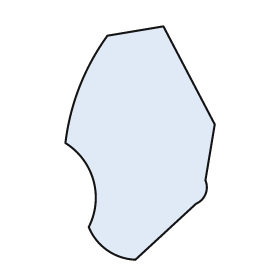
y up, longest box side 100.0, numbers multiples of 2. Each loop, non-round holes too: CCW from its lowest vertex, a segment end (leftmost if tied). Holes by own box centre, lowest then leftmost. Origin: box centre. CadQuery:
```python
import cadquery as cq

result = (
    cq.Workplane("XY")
    .moveTo(-2.0, -50.0)
    .lineTo(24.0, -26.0)
    .threePointArc((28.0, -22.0), (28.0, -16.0))
    .lineTo(32.0, 8.0)
    .lineTo(10.0, 50.0)
    .lineTo(-14.0, 46.0)
    .threePointArc((-26.0, 24.0), (-32.0, 0.0))
    .threePointArc((-20.0, -16.0), (-22.0, -36.0))
    .threePointArc((-14.0, -46.0), (-2.0, -50.0))
    .close()
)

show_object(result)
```